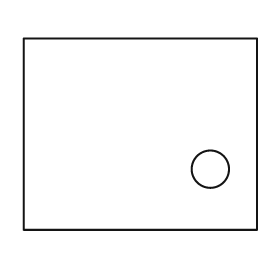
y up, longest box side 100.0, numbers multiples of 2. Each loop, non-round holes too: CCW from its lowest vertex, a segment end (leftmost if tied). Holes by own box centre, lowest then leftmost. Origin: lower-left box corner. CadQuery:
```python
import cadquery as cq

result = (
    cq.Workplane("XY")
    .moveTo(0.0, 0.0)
    .lineTo(100.0, 0.0)
    .lineTo(100.0, 82.0)
    .lineTo(0.0, 82.0)
    .close()
    .moveTo(80.0, 26.0)
    .circle(8.0)
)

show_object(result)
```